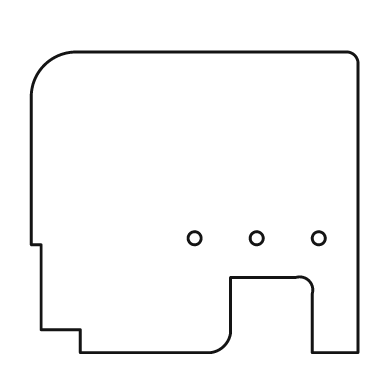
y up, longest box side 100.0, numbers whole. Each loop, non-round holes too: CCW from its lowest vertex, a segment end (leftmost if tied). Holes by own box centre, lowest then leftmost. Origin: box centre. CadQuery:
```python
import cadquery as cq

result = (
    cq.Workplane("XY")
    .moveTo(-35.0, -46.0)
    .lineTo(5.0, -46.0)
    .threePointArc((9.0, -44.0), (11.0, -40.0))
    .lineTo(11.0, -23.0)
    .lineTo(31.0, -23.0)
    .threePointArc((35.0, -24.0), (36.0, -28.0))
    .lineTo(36.0, -46.0)
    .lineTo(50.0, -46.0)
    .lineTo(50.0, 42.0)
    .threePointArc((49.0, 45.0), (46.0, 46.0))
    .lineTo(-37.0, 46.0)
    .threePointArc((-46.0, 42.0), (-50.0, 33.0))
    .lineTo(-50.0, -13.0)
    .lineTo(-47.0, -13.0)
    .lineTo(-47.0, -39.0)
    .lineTo(-35.0, -39.0)
    .close()
    .moveTo(0.0, -11.0)
    .circle(2.0)
    .moveTo(19.0, -11.0)
    .circle(2.0)
    .moveTo(38.0, -11.0)
    .circle(2.0)
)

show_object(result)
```